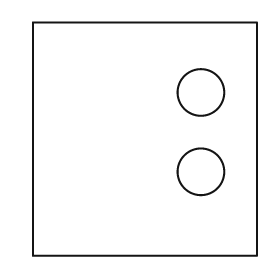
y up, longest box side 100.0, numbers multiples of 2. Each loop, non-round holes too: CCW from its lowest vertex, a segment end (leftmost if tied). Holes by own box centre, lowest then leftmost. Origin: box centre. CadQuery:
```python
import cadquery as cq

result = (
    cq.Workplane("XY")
    .moveTo(-48.0, -50.0)
    .lineTo(48.0, -50.0)
    .lineTo(48.0, 50.0)
    .lineTo(-48.0, 50.0)
    .close()
    .moveTo(24.0, -14.0)
    .circle(10.0)
    .moveTo(24.0, 20.0)
    .circle(10.0)
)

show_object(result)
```